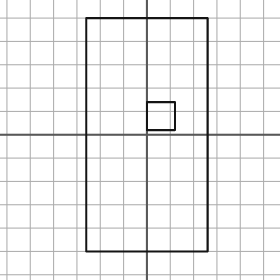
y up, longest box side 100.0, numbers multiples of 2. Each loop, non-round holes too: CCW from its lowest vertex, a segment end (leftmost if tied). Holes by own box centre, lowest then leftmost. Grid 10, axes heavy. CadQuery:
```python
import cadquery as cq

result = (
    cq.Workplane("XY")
    .moveTo(-26.0, -50.0)
    .lineTo(26.0, -50.0)
    .lineTo(26.0, 50.0)
    .lineTo(-26.0, 50.0)
    .close()
    .moveTo(0.0, 2.0)
    .lineTo(12.0, 2.0)
    .lineTo(12.0, 14.0)
    .lineTo(0.0, 14.0)
    .close()
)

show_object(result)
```